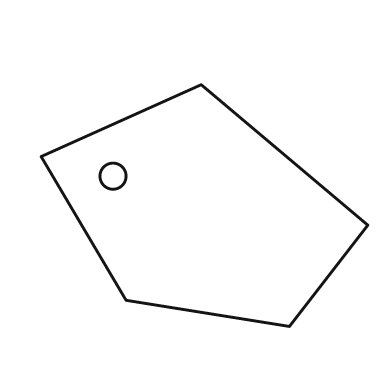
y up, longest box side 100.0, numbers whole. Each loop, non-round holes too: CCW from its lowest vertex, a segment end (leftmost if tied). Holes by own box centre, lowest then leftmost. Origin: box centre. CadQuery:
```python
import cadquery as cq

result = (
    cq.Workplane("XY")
    .moveTo(26.0, -37.0)
    .lineTo(50.0, -6.0)
    .lineTo(-1.0, 37.0)
    .lineTo(-50.0, 15.0)
    .lineTo(-24.0, -29.0)
    .close()
    .moveTo(-28.0, 9.0)
    .circle(4.0)
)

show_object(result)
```